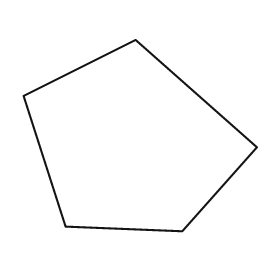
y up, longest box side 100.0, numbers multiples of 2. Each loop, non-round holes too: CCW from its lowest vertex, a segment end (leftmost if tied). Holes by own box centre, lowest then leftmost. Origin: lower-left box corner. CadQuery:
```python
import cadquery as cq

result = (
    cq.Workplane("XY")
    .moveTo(68.0, 0.0)
    .lineTo(100.0, 36.0)
    .lineTo(48.0, 82.0)
    .lineTo(0.0, 58.0)
    .lineTo(18.0, 2.0)
    .close()
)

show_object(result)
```